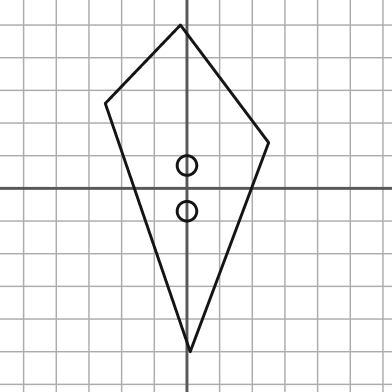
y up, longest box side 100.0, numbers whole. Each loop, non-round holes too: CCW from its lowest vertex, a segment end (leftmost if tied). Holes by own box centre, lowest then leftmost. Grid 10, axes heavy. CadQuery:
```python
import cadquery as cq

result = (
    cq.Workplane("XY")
    .moveTo(1.0, -50.0)
    .lineTo(25.0, 14.0)
    .lineTo(-2.0, 50.0)
    .lineTo(-25.0, 26.0)
    .close()
    .moveTo(0.0, -7.0)
    .circle(3.0)
    .moveTo(0.0, 7.0)
    .circle(3.0)
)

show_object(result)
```